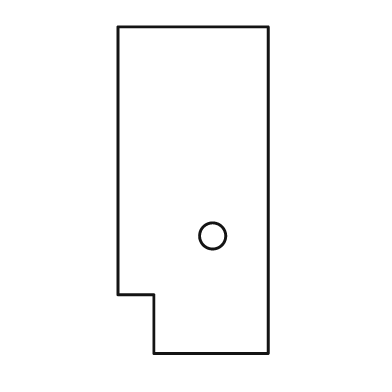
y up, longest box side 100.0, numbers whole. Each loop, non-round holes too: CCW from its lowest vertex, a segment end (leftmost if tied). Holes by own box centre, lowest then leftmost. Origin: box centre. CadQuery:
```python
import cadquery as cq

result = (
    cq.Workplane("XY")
    .moveTo(-12.0, -50.0)
    .lineTo(23.0, -50.0)
    .lineTo(23.0, 50.0)
    .lineTo(-23.0, 50.0)
    .lineTo(-23.0, -32.0)
    .lineTo(-12.0, -32.0)
    .close()
    .moveTo(6.0, -14.0)
    .circle(4.0)
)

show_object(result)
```